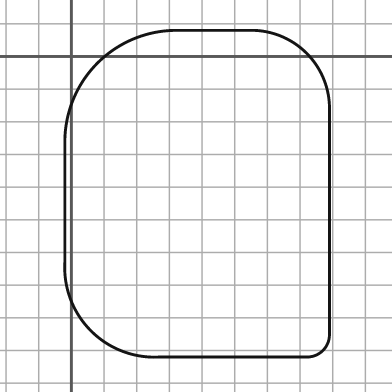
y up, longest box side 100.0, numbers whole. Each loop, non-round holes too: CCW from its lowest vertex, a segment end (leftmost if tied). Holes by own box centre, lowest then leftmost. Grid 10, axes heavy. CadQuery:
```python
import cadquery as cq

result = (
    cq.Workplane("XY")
    .moveTo(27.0, -92.0)
    .lineTo(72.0, -92.0)
    .threePointArc((77.0, -90.0), (79.0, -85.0))
    .lineTo(79.0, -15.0)
    .threePointArc((72.0, 1.0), (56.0, 8.0))
    .lineTo(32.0, 8.0)
    .threePointArc((8.0, -2.0), (-2.0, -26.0))
    .lineTo(-2.0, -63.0)
    .threePointArc((6.0, -84.0), (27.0, -92.0))
    .close()
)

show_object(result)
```